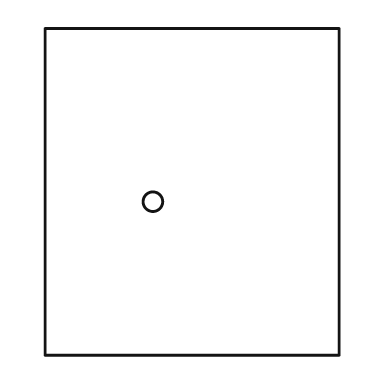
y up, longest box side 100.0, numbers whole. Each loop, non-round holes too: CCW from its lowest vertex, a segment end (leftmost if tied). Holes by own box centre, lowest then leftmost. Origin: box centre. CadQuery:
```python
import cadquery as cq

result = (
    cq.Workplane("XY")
    .moveTo(-45.0, -50.0)
    .lineTo(45.0, -50.0)
    .lineTo(45.0, 50.0)
    .lineTo(-45.0, 50.0)
    .close()
    .moveTo(-12.0, -3.0)
    .circle(3.0)
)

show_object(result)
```